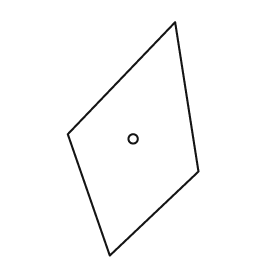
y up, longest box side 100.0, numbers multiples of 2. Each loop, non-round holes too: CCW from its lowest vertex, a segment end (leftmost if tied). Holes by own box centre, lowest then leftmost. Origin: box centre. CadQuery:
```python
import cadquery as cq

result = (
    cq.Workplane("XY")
    .moveTo(-10.0, -50.0)
    .lineTo(28.0, -14.0)
    .lineTo(18.0, 50.0)
    .lineTo(-28.0, 2.0)
    .close()
    .moveTo(0.0, 0.0)
    .circle(2.0)
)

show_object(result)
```